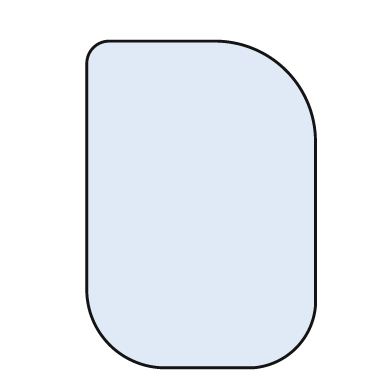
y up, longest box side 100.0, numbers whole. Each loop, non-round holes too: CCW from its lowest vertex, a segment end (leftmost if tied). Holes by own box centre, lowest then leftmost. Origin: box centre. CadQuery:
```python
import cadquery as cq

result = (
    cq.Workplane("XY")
    .moveTo(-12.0, -50.0)
    .lineTo(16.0, -50.0)
    .threePointArc((29.0, -44.0), (35.0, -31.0))
    .lineTo(35.0, 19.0)
    .threePointArc((26.0, 41.0), (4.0, 50.0))
    .lineTo(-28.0, 50.0)
    .threePointArc((-33.0, 48.0), (-35.0, 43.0))
    .lineTo(-35.0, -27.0)
    .threePointArc((-28.0, -43.0), (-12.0, -50.0))
    .close()
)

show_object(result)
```